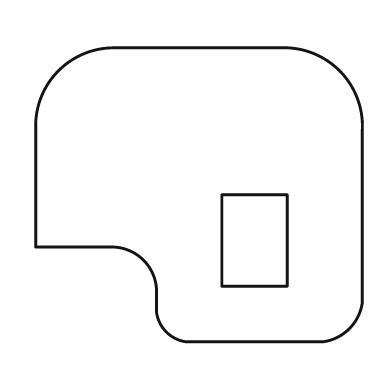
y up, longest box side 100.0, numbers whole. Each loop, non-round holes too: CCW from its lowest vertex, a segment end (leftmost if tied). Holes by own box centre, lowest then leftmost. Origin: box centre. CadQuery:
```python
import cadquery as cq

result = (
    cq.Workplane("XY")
    .moveTo(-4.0, -45.0)
    .lineTo(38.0, -45.0)
    .threePointArc((46.0, -41.0), (50.0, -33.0))
    .lineTo(50.0, 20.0)
    .threePointArc((43.0, 38.0), (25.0, 45.0))
    .lineTo(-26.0, 45.0)
    .threePointArc((-43.0, 38.0), (-50.0, 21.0))
    .lineTo(-50.0, -16.0)
    .lineTo(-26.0, -16.0)
    .threePointArc((-17.0, -20.0), (-13.0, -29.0))
    .lineTo(-13.0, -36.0)
    .threePointArc((-10.0, -42.0), (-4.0, -45.0))
    .close()
    .moveTo(7.0, -28.0)
    .lineTo(27.0, -28.0)
    .lineTo(27.0, 0.0)
    .lineTo(7.0, 0.0)
    .close()
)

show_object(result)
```